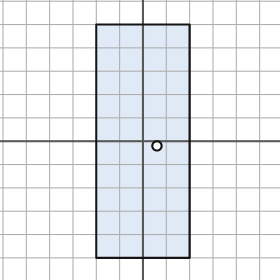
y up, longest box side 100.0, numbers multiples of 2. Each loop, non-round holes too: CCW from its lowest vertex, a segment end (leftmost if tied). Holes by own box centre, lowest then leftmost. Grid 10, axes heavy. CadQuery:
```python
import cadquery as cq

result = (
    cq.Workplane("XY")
    .moveTo(-20.0, -50.0)
    .lineTo(20.0, -50.0)
    .lineTo(20.0, 50.0)
    .lineTo(-20.0, 50.0)
    .close()
    .moveTo(6.0, -2.0)
    .circle(2.0)
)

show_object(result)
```